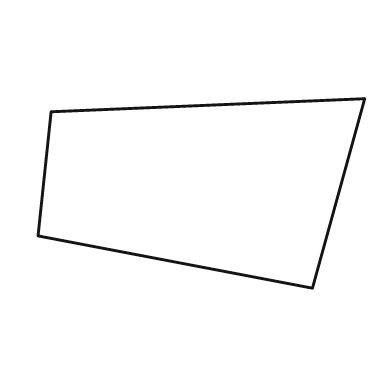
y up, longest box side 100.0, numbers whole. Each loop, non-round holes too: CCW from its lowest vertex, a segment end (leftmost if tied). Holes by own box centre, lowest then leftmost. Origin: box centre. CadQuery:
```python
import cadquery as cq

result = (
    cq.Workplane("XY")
    .moveTo(34.0, -29.0)
    .lineTo(50.0, 29.0)
    .lineTo(-46.0, 25.0)
    .lineTo(-50.0, -13.0)
    .close()
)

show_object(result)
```